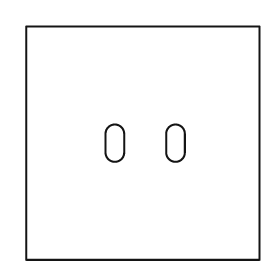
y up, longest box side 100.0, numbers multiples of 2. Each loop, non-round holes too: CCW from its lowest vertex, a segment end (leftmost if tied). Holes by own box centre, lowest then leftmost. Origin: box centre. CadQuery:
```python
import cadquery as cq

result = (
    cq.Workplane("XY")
    .moveTo(-50.0, -50.0)
    .lineTo(50.0, -50.0)
    .lineTo(50.0, 50.0)
    .lineTo(-50.0, 50.0)
    .close()
    .moveTo(-16.0, -4.0)
    .threePointArc((-12.0, -8.0), (-8.0, -4.0))
    .lineTo(-8.0, 4.0)
    .threePointArc((-12.0, 8.0), (-16.0, 4.0))
    .close()
    .moveTo(10.0, -4.0)
    .threePointArc((14.0, -8.0), (18.0, -4.0))
    .lineTo(18.0, 4.0)
    .threePointArc((14.0, 8.0), (10.0, 4.0))
    .close()
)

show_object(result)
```